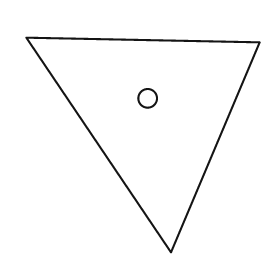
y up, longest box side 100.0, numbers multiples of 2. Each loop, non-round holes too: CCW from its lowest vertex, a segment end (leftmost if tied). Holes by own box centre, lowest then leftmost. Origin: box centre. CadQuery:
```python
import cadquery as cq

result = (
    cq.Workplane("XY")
    .moveTo(12.0, -46.0)
    .lineTo(50.0, 44.0)
    .lineTo(-50.0, 46.0)
    .close()
    .moveTo(2.0, 20.0)
    .circle(4.0)
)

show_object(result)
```